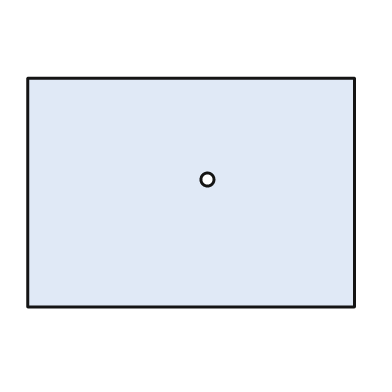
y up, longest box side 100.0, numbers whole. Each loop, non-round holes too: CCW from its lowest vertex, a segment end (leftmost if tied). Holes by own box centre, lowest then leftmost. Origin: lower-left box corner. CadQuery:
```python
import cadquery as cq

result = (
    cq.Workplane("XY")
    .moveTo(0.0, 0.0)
    .lineTo(100.0, 0.0)
    .lineTo(100.0, 70.0)
    .lineTo(0.0, 70.0)
    .close()
    .moveTo(55.0, 39.0)
    .circle(2.0)
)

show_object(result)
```